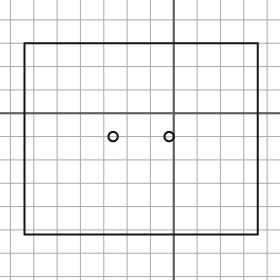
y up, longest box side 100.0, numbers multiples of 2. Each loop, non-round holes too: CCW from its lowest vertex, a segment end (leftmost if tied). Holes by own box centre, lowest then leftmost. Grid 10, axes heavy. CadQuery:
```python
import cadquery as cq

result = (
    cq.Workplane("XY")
    .moveTo(-64.0, -52.0)
    .lineTo(36.0, -52.0)
    .lineTo(36.0, 30.0)
    .lineTo(-64.0, 30.0)
    .close()
    .moveTo(-26.0, -10.0)
    .circle(2.0)
    .moveTo(-2.0, -10.0)
    .circle(2.0)
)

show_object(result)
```